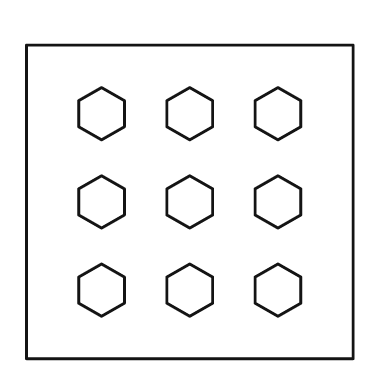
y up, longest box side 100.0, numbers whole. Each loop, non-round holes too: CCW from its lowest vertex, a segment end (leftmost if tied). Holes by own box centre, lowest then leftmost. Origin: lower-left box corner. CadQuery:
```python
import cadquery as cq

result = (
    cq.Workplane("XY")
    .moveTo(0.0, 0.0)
    .lineTo(100.0, 0.0)
    .lineTo(100.0, 96.0)
    .lineTo(0.0, 96.0)
    .close()
    .moveTo(23.0, 13.0)
    .lineTo(30.0, 17.0)
    .lineTo(30.0, 25.0)
    .lineTo(23.0, 29.0)
    .lineTo(16.0, 25.0)
    .lineTo(16.0, 17.0)
    .close()
    .moveTo(50.0, 13.0)
    .lineTo(57.0, 17.0)
    .lineTo(57.0, 25.0)
    .lineTo(50.0, 29.0)
    .lineTo(43.0, 25.0)
    .lineTo(43.0, 17.0)
    .close()
    .moveTo(77.0, 13.0)
    .lineTo(84.0, 17.0)
    .lineTo(84.0, 25.0)
    .lineTo(77.0, 29.0)
    .lineTo(70.0, 25.0)
    .lineTo(70.0, 17.0)
    .close()
    .moveTo(23.0, 40.0)
    .lineTo(30.0, 44.0)
    .lineTo(30.0, 52.0)
    .lineTo(23.0, 56.0)
    .lineTo(16.0, 52.0)
    .lineTo(16.0, 44.0)
    .close()
    .moveTo(50.0, 40.0)
    .lineTo(57.0, 44.0)
    .lineTo(57.0, 52.0)
    .lineTo(50.0, 56.0)
    .lineTo(43.0, 52.0)
    .lineTo(43.0, 44.0)
    .close()
    .moveTo(77.0, 40.0)
    .lineTo(84.0, 44.0)
    .lineTo(84.0, 52.0)
    .lineTo(77.0, 56.0)
    .lineTo(70.0, 52.0)
    .lineTo(70.0, 44.0)
    .close()
    .moveTo(23.0, 67.0)
    .lineTo(30.0, 71.0)
    .lineTo(30.0, 79.0)
    .lineTo(23.0, 83.0)
    .lineTo(16.0, 79.0)
    .lineTo(16.0, 71.0)
    .close()
    .moveTo(50.0, 67.0)
    .lineTo(57.0, 71.0)
    .lineTo(57.0, 79.0)
    .lineTo(50.0, 83.0)
    .lineTo(43.0, 79.0)
    .lineTo(43.0, 71.0)
    .close()
    .moveTo(77.0, 67.0)
    .lineTo(84.0, 71.0)
    .lineTo(84.0, 79.0)
    .lineTo(77.0, 83.0)
    .lineTo(70.0, 79.0)
    .lineTo(70.0, 71.0)
    .close()
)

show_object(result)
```